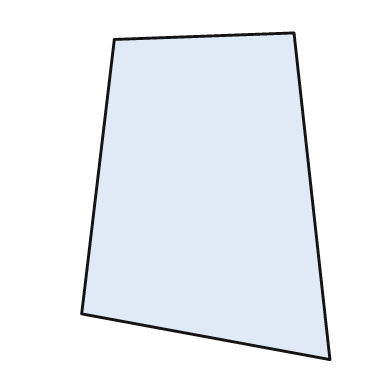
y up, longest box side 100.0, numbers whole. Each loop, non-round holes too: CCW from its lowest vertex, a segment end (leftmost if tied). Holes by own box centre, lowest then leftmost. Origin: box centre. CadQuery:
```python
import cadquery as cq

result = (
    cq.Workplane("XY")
    .moveTo(38.0, -50.0)
    .lineTo(27.0, 50.0)
    .lineTo(-28.0, 48.0)
    .lineTo(-38.0, -36.0)
    .close()
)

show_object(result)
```